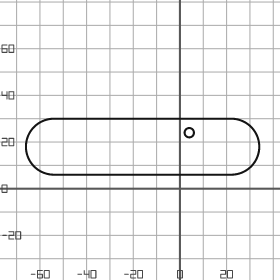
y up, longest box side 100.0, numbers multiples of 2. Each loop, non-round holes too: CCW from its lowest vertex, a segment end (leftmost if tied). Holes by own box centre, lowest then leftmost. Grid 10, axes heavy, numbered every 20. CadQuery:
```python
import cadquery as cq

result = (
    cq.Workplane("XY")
    .moveTo(-54.0, 6.0)
    .lineTo(22.0, 6.0)
    .threePointArc((34.0, 18.0), (22.0, 30.0))
    .lineTo(-54.0, 30.0)
    .threePointArc((-66.0, 18.0), (-54.0, 6.0))
    .close()
    .moveTo(4.0, 24.0)
    .circle(2.0)
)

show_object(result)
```